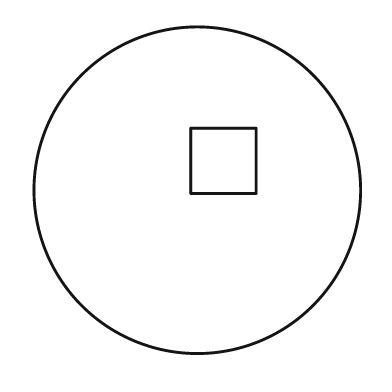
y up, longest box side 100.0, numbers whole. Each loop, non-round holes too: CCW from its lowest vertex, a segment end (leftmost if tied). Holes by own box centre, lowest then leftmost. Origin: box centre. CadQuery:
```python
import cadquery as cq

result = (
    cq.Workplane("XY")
    .moveTo(0.0, 0.0)
    .circle(50.0)
    .moveTo(-2.0, -1.0)
    .lineTo(18.0, -1.0)
    .lineTo(18.0, 19.0)
    .lineTo(-2.0, 19.0)
    .close()
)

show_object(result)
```